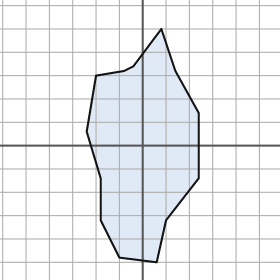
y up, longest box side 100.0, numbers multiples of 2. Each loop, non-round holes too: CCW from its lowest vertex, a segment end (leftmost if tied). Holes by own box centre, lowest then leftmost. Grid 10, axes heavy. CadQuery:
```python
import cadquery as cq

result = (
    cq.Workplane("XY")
    .moveTo(6.0, -50.0)
    .lineTo(10.0, -32.0)
    .lineTo(24.0, -14.0)
    .lineTo(24.0, 14.0)
    .lineTo(14.0, 32.0)
    .lineTo(8.0, 50.0)
    .lineTo(-4.0, 34.0)
    .lineTo(-8.0, 32.0)
    .lineTo(-20.0, 30.0)
    .lineTo(-24.0, 6.0)
    .lineTo(-18.0, -14.0)
    .lineTo(-18.0, -32.0)
    .lineTo(-10.0, -48.0)
    .close()
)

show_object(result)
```